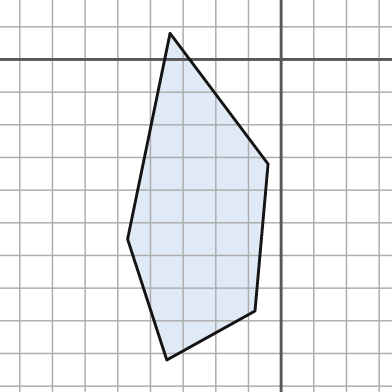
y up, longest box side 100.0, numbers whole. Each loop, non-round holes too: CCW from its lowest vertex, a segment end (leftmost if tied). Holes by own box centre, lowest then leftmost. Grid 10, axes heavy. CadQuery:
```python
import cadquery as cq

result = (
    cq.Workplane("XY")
    .moveTo(-35.0, -92.0)
    .lineTo(-8.0, -77.0)
    .lineTo(-4.0, -32.0)
    .lineTo(-34.0, 8.0)
    .lineTo(-47.0, -55.0)
    .close()
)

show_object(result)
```